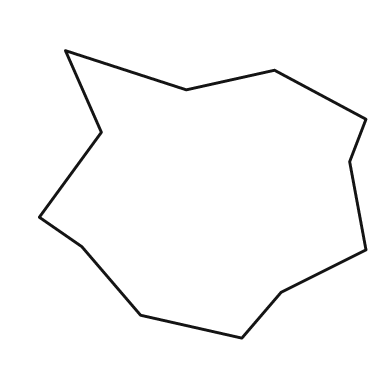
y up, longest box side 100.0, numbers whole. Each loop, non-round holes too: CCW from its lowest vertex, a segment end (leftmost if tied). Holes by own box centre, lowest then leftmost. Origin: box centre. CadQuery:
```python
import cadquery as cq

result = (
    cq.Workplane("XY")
    .moveTo(12.0, -44.0)
    .lineTo(24.0, -30.0)
    .lineTo(50.0, -17.0)
    .lineTo(45.0, 10.0)
    .lineTo(50.0, 23.0)
    .lineTo(22.0, 38.0)
    .lineTo(-5.0, 32.0)
    .lineTo(-42.0, 44.0)
    .lineTo(-31.0, 19.0)
    .lineTo(-50.0, -7.0)
    .lineTo(-37.0, -16.0)
    .lineTo(-19.0, -37.0)
    .close()
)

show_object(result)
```